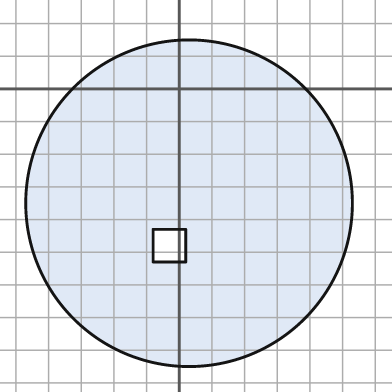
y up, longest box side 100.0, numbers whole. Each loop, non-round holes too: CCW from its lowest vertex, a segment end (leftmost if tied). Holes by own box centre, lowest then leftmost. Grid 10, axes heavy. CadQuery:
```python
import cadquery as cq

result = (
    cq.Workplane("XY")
    .moveTo(3.0, -35.0)
    .circle(50.0)
    .moveTo(-8.0, -53.0)
    .lineTo(2.0, -53.0)
    .lineTo(2.0, -43.0)
    .lineTo(-8.0, -43.0)
    .close()
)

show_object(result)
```